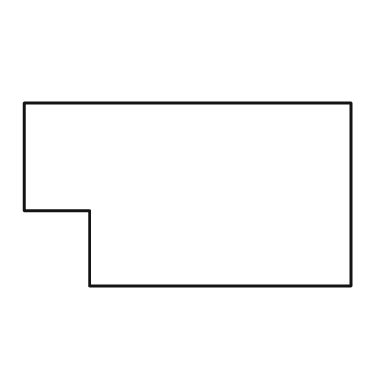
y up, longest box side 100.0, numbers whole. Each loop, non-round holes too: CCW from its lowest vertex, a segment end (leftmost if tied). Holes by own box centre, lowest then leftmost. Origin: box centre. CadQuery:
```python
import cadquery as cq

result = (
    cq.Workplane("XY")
    .moveTo(-30.0, -28.0)
    .lineTo(50.0, -28.0)
    .lineTo(50.0, 28.0)
    .lineTo(-50.0, 28.0)
    .lineTo(-50.0, -5.0)
    .lineTo(-30.0, -5.0)
    .close()
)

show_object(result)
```